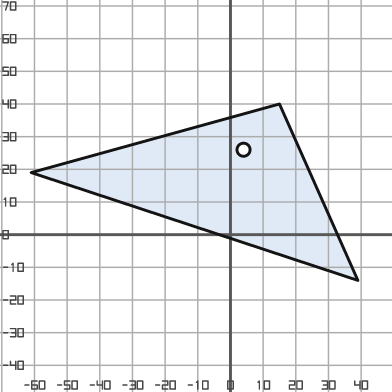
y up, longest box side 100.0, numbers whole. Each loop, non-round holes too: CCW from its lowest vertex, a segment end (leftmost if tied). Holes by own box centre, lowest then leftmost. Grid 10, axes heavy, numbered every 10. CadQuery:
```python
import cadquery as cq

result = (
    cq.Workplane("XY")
    .moveTo(39.0, -14.0)
    .lineTo(15.0, 40.0)
    .lineTo(-61.0, 19.0)
    .close()
    .moveTo(4.0, 26.0)
    .circle(2.0)
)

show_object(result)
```